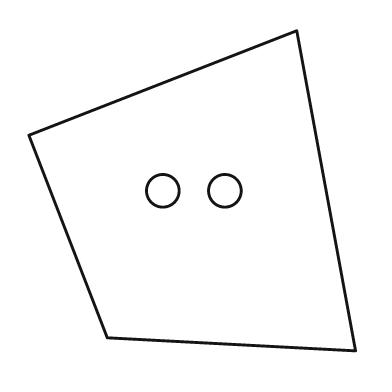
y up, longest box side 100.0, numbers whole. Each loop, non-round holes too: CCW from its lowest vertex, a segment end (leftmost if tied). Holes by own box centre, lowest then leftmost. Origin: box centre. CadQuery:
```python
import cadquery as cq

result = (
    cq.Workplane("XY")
    .moveTo(50.0, -49.0)
    .lineTo(32.0, 49.0)
    .lineTo(-50.0, 17.0)
    .lineTo(-26.0, -45.0)
    .close()
    .moveTo(-9.0, 0.0)
    .circle(5.0)
    .moveTo(10.0, 0.0)
    .circle(5.0)
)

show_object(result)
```